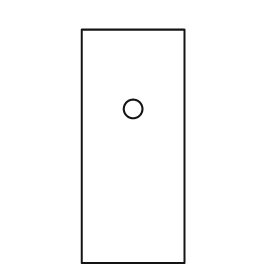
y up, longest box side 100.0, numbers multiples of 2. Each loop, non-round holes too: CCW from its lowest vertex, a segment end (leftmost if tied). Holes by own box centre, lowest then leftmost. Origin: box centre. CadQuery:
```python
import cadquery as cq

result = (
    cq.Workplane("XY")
    .moveTo(-22.0, -50.0)
    .lineTo(22.0, -50.0)
    .lineTo(22.0, 50.0)
    .lineTo(-22.0, 50.0)
    .close()
    .moveTo(0.0, 16.0)
    .circle(4.0)
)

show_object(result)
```